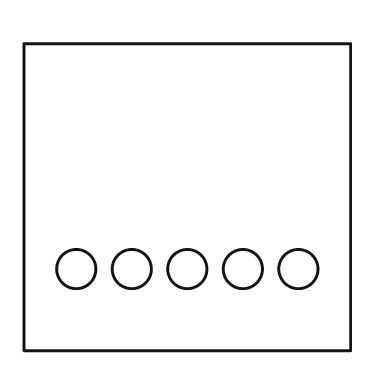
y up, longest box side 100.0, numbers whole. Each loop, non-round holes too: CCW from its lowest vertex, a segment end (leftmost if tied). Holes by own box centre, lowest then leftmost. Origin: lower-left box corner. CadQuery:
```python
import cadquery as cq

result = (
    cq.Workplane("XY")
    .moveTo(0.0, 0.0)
    .lineTo(100.0, 0.0)
    .lineTo(100.0, 94.0)
    .lineTo(0.0, 94.0)
    .close()
    .moveTo(16.0, 25.0)
    .circle(6.0)
    .moveTo(33.0, 25.0)
    .circle(6.0)
    .moveTo(50.0, 25.0)
    .circle(6.0)
    .moveTo(67.0, 25.0)
    .circle(6.0)
    .moveTo(84.0, 25.0)
    .circle(6.0)
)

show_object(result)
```